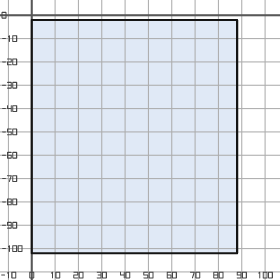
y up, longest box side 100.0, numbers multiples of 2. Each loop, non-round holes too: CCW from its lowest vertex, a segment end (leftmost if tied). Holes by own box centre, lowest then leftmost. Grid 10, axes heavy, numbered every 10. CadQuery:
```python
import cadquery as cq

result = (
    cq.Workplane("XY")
    .moveTo(0.0, -102.0)
    .lineTo(88.0, -102.0)
    .lineTo(88.0, -2.0)
    .lineTo(0.0, -2.0)
    .close()
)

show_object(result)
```